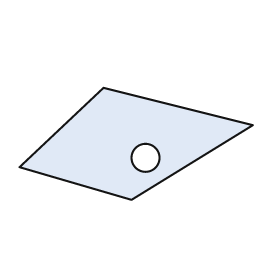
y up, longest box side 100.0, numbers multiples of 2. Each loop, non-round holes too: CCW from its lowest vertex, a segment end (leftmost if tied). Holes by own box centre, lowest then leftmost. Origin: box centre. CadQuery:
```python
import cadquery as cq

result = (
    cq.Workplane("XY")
    .moveTo(-2.0, -24.0)
    .lineTo(50.0, 8.0)
    .lineTo(-14.0, 24.0)
    .lineTo(-50.0, -10.0)
    .close()
    .moveTo(4.0, -6.0)
    .circle(6.0)
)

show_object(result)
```